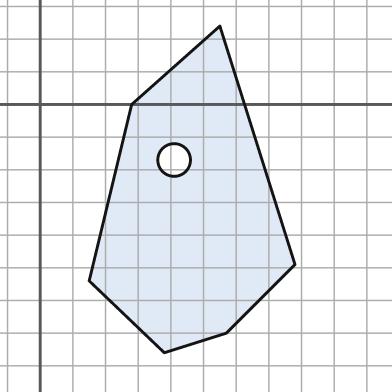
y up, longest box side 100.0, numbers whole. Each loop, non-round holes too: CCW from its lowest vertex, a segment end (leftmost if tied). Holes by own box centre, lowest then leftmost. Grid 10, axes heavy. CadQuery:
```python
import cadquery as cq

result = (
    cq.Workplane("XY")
    .moveTo(38.0, -76.0)
    .lineTo(57.0, -70.0)
    .lineTo(78.0, -49.0)
    .lineTo(55.0, 24.0)
    .lineTo(28.0, 0.0)
    .lineTo(15.0, -54.0)
    .close()
    .moveTo(41.0, -17.0)
    .circle(5.0)
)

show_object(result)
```